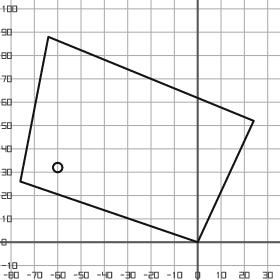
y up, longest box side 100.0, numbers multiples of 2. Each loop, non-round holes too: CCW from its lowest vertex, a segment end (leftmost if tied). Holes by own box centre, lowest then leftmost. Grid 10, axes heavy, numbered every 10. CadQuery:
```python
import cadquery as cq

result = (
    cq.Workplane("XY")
    .moveTo(0.0, 0.0)
    .lineTo(24.0, 52.0)
    .lineTo(-64.0, 88.0)
    .lineTo(-76.0, 26.0)
    .close()
    .moveTo(-60.0, 32.0)
    .circle(2.0)
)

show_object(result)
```